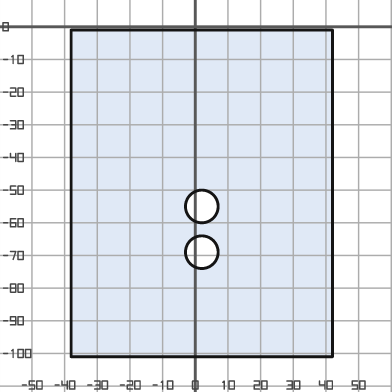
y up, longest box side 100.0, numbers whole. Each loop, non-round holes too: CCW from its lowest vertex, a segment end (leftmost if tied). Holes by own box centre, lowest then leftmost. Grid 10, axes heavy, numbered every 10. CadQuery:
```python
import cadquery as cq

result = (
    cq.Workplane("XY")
    .moveTo(-38.0, -101.0)
    .lineTo(42.0, -101.0)
    .lineTo(42.0, -1.0)
    .lineTo(-38.0, -1.0)
    .close()
    .moveTo(2.0, -69.0)
    .circle(5.0)
    .moveTo(2.0, -55.0)
    .circle(5.0)
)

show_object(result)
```